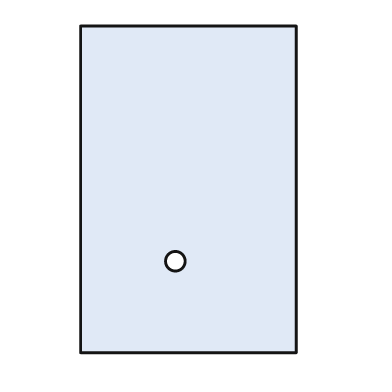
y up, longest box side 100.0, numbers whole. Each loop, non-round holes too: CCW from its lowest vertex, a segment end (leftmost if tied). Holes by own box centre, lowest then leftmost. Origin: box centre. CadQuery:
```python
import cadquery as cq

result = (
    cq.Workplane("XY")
    .moveTo(-33.0, -50.0)
    .lineTo(33.0, -50.0)
    .lineTo(33.0, 50.0)
    .lineTo(-33.0, 50.0)
    .close()
    .moveTo(-4.0, -22.0)
    .circle(3.0)
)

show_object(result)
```